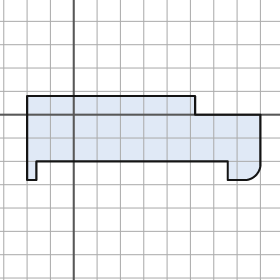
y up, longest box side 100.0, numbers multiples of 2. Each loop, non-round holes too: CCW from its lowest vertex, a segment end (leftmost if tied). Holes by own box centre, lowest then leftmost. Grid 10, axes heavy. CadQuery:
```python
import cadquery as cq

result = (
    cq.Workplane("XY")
    .moveTo(-20.0, -28.0)
    .lineTo(-16.0, -28.0)
    .lineTo(-16.0, -20.0)
    .lineTo(66.0, -20.0)
    .lineTo(66.0, -28.0)
    .lineTo(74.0, -28.0)
    .threePointArc((78.0, -26.0), (80.0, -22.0))
    .lineTo(80.0, 0.0)
    .lineTo(52.0, 0.0)
    .lineTo(52.0, 8.0)
    .lineTo(-20.0, 8.0)
    .close()
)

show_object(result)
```